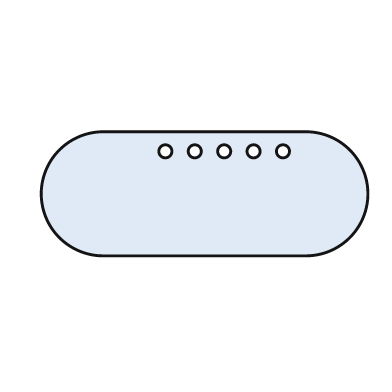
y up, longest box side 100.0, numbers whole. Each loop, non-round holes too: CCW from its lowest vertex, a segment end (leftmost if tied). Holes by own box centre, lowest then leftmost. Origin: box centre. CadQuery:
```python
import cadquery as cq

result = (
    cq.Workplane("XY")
    .moveTo(-31.0, -19.0)
    .lineTo(31.0, -19.0)
    .threePointArc((50.0, 0.0), (31.0, 19.0))
    .lineTo(-31.0, 19.0)
    .threePointArc((-50.0, 0.0), (-31.0, -19.0))
    .close()
    .moveTo(-12.0, 13.0)
    .circle(2.0)
    .moveTo(-3.0, 13.0)
    .circle(2.0)
    .moveTo(6.0, 13.0)
    .circle(2.0)
    .moveTo(15.0, 13.0)
    .circle(2.0)
    .moveTo(24.0, 13.0)
    .circle(2.0)
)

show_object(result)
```